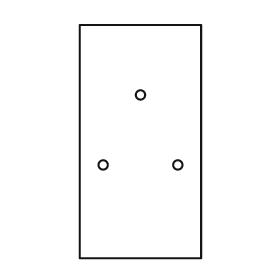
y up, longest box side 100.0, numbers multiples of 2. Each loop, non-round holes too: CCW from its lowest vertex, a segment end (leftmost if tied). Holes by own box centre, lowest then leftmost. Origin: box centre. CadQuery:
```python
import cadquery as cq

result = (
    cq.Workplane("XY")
    .moveTo(-26.0, -50.0)
    .lineTo(26.0, -50.0)
    .lineTo(26.0, 50.0)
    .lineTo(-26.0, 50.0)
    .close()
    .moveTo(-16.0, -10.0)
    .circle(2.0)
    .moveTo(16.0, -10.0)
    .circle(2.0)
    .moveTo(0.0, 20.0)
    .circle(2.0)
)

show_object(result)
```